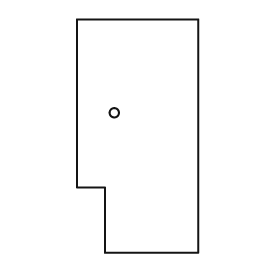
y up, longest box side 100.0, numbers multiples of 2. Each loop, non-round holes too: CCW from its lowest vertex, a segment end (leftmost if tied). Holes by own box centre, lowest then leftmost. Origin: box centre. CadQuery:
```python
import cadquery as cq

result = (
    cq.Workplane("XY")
    .moveTo(-14.0, -50.0)
    .lineTo(26.0, -50.0)
    .lineTo(26.0, 50.0)
    .lineTo(-26.0, 50.0)
    .lineTo(-26.0, -22.0)
    .lineTo(-14.0, -22.0)
    .close()
    .moveTo(-10.0, 10.0)
    .circle(2.0)
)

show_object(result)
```